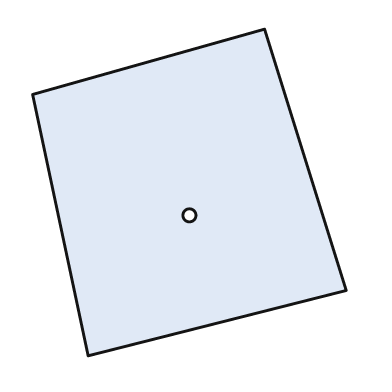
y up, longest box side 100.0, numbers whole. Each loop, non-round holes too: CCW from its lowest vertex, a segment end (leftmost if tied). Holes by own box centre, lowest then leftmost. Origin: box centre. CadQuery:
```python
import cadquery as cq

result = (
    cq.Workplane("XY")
    .moveTo(-31.0, -50.0)
    .lineTo(48.0, -30.0)
    .lineTo(23.0, 50.0)
    .lineTo(-48.0, 30.0)
    .close()
    .moveTo(0.0, -7.0)
    .circle(2.0)
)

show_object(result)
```